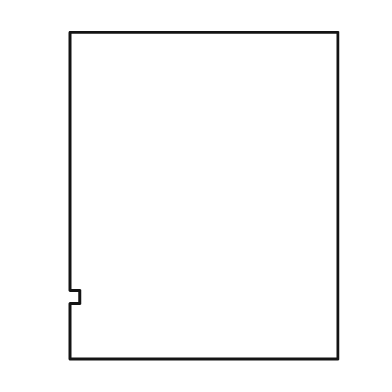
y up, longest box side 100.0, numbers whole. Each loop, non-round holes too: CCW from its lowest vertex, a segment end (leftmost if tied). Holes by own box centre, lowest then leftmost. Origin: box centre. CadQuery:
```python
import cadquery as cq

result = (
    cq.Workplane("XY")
    .moveTo(-41.0, -50.0)
    .lineTo(41.0, -50.0)
    .lineTo(41.0, 50.0)
    .lineTo(-41.0, 50.0)
    .lineTo(-41.0, -29.0)
    .lineTo(-38.0, -29.0)
    .lineTo(-38.0, -33.0)
    .lineTo(-41.0, -33.0)
    .close()
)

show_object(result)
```